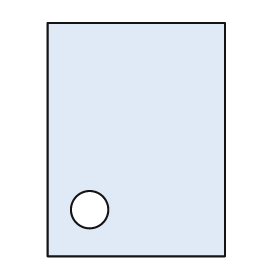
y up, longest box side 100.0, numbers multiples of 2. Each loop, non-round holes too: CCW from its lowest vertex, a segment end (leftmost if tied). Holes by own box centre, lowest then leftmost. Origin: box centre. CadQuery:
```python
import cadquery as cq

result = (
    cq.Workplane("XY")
    .moveTo(-38.0, -50.0)
    .lineTo(38.0, -50.0)
    .lineTo(38.0, 50.0)
    .lineTo(-38.0, 50.0)
    .close()
    .moveTo(-20.0, -30.0)
    .circle(8.0)
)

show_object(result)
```